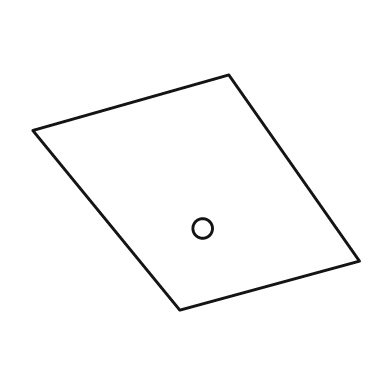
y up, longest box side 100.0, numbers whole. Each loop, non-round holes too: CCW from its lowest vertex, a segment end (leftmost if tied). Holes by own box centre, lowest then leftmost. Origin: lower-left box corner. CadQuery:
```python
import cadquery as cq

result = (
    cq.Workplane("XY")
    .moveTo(45.0, 0.0)
    .lineTo(100.0, 15.0)
    .lineTo(60.0, 72.0)
    .lineTo(0.0, 55.0)
    .close()
    .moveTo(52.0, 25.0)
    .circle(3.0)
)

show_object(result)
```